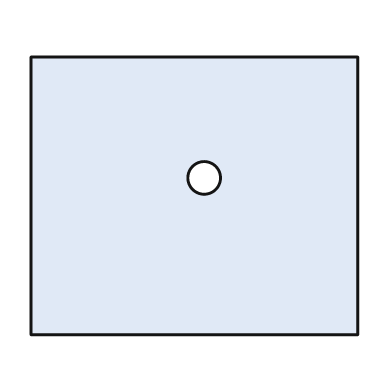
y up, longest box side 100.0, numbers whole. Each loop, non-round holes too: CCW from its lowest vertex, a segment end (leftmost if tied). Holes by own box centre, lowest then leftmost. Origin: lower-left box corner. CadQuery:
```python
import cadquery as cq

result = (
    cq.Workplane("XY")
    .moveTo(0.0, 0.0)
    .lineTo(100.0, 0.0)
    .lineTo(100.0, 85.0)
    .lineTo(0.0, 85.0)
    .close()
    .moveTo(53.0, 48.0)
    .circle(5.0)
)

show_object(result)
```